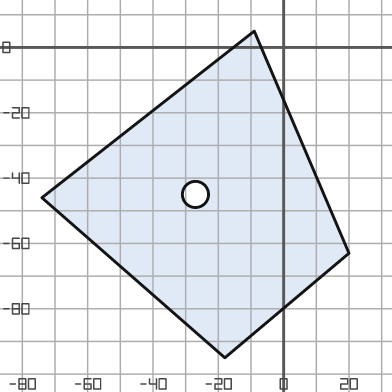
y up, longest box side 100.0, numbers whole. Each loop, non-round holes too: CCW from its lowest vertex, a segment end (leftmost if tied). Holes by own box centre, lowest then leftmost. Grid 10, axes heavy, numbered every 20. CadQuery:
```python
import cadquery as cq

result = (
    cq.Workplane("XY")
    .moveTo(-18.0, -95.0)
    .lineTo(20.0, -63.0)
    .lineTo(-9.0, 5.0)
    .lineTo(-74.0, -46.0)
    .close()
    .moveTo(-27.0, -45.0)
    .circle(4.0)
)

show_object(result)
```